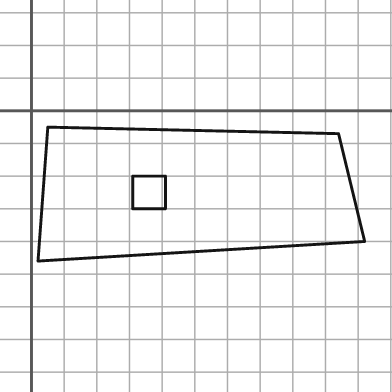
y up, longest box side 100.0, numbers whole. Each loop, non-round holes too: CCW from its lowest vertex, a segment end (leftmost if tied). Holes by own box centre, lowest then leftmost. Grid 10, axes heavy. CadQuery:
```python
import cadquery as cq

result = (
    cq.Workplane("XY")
    .moveTo(2.0, -46.0)
    .lineTo(102.0, -40.0)
    .lineTo(94.0, -7.0)
    .lineTo(5.0, -5.0)
    .close()
    .moveTo(31.0, -30.0)
    .lineTo(41.0, -30.0)
    .lineTo(41.0, -20.0)
    .lineTo(31.0, -20.0)
    .close()
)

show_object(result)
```